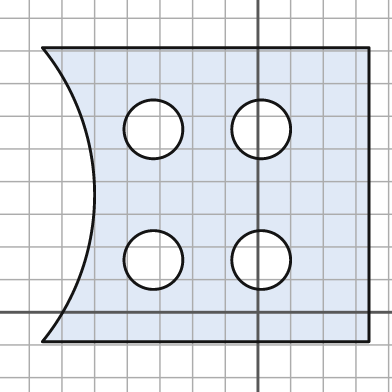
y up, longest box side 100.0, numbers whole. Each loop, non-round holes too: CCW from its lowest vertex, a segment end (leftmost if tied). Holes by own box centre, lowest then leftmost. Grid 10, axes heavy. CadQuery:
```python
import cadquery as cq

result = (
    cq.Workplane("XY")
    .moveTo(-66.0, -9.0)
    .lineTo(34.0, -9.0)
    .lineTo(34.0, 81.0)
    .lineTo(-66.0, 81.0)
    .threePointArc((-50.0, 36.0), (-66.0, -9.0))
    .close()
    .moveTo(-32.0, 16.0)
    .circle(9.0)
    .moveTo(1.0, 16.0)
    .circle(9.0)
    .moveTo(-32.0, 56.0)
    .circle(9.0)
    .moveTo(1.0, 56.0)
    .circle(9.0)
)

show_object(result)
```